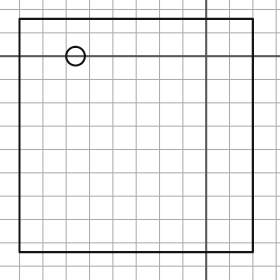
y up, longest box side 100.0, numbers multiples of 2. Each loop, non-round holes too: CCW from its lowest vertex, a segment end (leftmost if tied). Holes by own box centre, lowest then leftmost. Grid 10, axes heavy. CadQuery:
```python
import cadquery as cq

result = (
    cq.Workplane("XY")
    .moveTo(-80.0, -84.0)
    .lineTo(20.0, -84.0)
    .lineTo(20.0, 16.0)
    .lineTo(-80.0, 16.0)
    .close()
    .moveTo(-56.0, 0.0)
    .circle(4.0)
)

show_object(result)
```